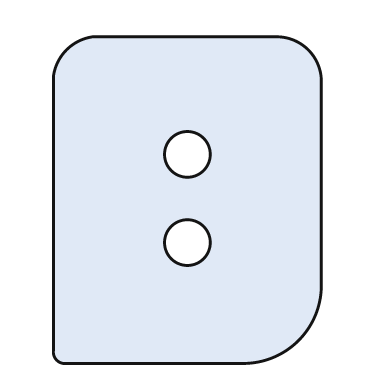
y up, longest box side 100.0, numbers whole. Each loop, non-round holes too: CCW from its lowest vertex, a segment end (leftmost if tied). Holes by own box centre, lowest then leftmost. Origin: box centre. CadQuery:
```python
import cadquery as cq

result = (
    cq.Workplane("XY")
    .moveTo(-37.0, -50.0)
    .lineTo(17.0, -50.0)
    .threePointArc((34.0, -43.0), (41.0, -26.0))
    .lineTo(41.0, 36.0)
    .threePointArc((37.0, 46.0), (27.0, 50.0))
    .lineTo(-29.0, 50.0)
    .threePointArc((-37.0, 46.0), (-41.0, 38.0))
    .lineTo(-41.0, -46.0)
    .threePointArc((-40.0, -49.0), (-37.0, -50.0))
    .close()
    .moveTo(0.0, -13.0)
    .circle(7.0)
    .moveTo(0.0, 14.0)
    .circle(7.0)
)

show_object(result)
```